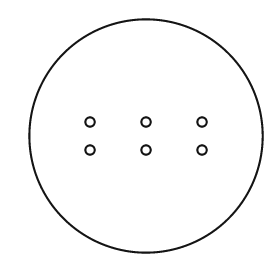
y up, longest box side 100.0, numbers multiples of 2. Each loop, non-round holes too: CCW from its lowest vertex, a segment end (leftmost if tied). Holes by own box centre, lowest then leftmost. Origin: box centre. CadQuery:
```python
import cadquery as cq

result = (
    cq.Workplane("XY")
    .moveTo(0.0, 0.0)
    .circle(50.0)
    .moveTo(-24.0, -6.0)
    .circle(2.0)
    .moveTo(0.0, -6.0)
    .circle(2.0)
    .moveTo(24.0, -6.0)
    .circle(2.0)
    .moveTo(-24.0, 6.0)
    .circle(2.0)
    .moveTo(0.0, 6.0)
    .circle(2.0)
    .moveTo(24.0, 6.0)
    .circle(2.0)
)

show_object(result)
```